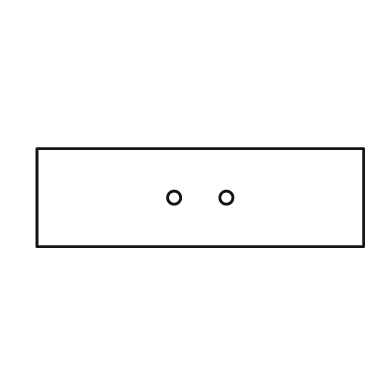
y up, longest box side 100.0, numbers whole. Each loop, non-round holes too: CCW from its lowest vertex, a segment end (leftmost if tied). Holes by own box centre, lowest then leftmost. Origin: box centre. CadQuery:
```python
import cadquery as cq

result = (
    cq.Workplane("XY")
    .moveTo(-50.0, -15.0)
    .lineTo(50.0, -15.0)
    .lineTo(50.0, 15.0)
    .lineTo(-50.0, 15.0)
    .close()
    .moveTo(-8.0, 0.0)
    .circle(2.0)
    .moveTo(8.0, 0.0)
    .circle(2.0)
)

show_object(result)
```